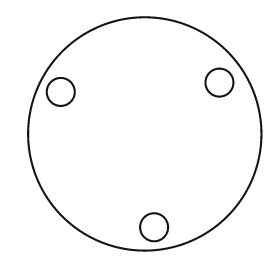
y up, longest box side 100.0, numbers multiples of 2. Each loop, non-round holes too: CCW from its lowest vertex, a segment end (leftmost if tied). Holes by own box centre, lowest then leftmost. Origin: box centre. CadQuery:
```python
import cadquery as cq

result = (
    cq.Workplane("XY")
    .moveTo(0.0, 0.0)
    .circle(50.0)
    .moveTo(4.0, -40.0)
    .circle(6.0)
    .moveTo(-36.0, 18.0)
    .circle(6.0)
    .moveTo(32.0, 22.0)
    .circle(6.0)
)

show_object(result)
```